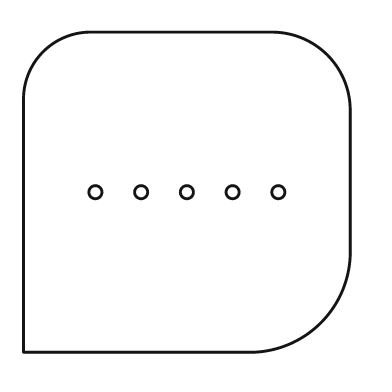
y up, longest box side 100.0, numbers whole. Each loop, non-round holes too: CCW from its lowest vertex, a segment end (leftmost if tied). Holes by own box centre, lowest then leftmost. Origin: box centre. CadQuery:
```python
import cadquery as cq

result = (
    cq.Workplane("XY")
    .moveTo(-50.0, -49.0)
    .lineTo(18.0, -49.0)
    .threePointArc((41.0, -40.0), (50.0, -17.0))
    .lineTo(50.0, 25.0)
    .threePointArc((43.0, 42.0), (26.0, 49.0))
    .lineTo(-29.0, 49.0)
    .threePointArc((-44.0, 43.0), (-50.0, 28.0))
    .close()
    .moveTo(-28.0, 0.0)
    .circle(2.0)
    .moveTo(-14.0, 0.0)
    .circle(2.0)
    .moveTo(0.0, 0.0)
    .circle(2.0)
    .moveTo(14.0, 0.0)
    .circle(2.0)
    .moveTo(28.0, 0.0)
    .circle(2.0)
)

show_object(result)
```